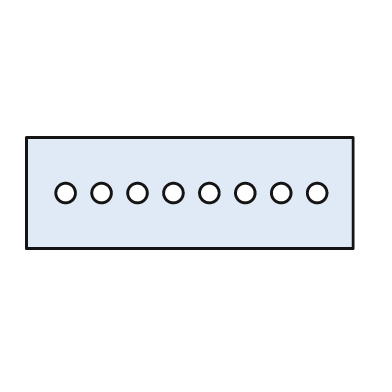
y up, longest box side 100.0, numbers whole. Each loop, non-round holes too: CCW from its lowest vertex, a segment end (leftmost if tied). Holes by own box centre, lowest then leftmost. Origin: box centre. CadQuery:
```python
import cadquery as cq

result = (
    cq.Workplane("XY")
    .moveTo(-50.0, -17.0)
    .lineTo(50.0, -17.0)
    .lineTo(50.0, 17.0)
    .lineTo(-50.0, 17.0)
    .close()
    .moveTo(-38.0, 0.0)
    .circle(3.0)
    .moveTo(-27.0, 0.0)
    .circle(3.0)
    .moveTo(-16.0, 0.0)
    .circle(3.0)
    .moveTo(-5.0, 0.0)
    .circle(3.0)
    .moveTo(6.0, 0.0)
    .circle(3.0)
    .moveTo(17.0, 0.0)
    .circle(3.0)
    .moveTo(28.0, 0.0)
    .circle(3.0)
    .moveTo(39.0, 0.0)
    .circle(3.0)
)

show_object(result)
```